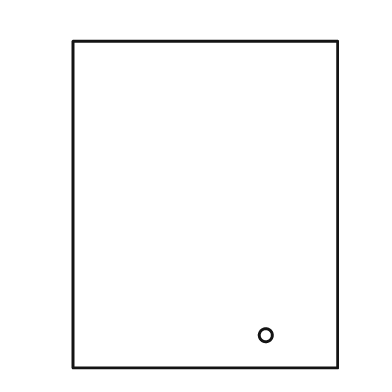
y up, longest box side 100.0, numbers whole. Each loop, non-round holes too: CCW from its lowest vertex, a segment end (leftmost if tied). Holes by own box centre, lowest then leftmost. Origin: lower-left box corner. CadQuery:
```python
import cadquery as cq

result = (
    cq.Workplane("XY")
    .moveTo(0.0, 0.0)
    .lineTo(81.0, 0.0)
    .lineTo(81.0, 100.0)
    .lineTo(0.0, 100.0)
    .close()
    .moveTo(59.0, 10.0)
    .circle(2.0)
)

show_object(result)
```